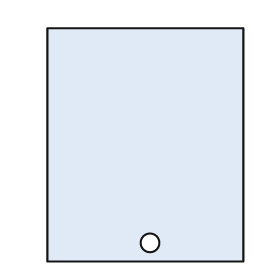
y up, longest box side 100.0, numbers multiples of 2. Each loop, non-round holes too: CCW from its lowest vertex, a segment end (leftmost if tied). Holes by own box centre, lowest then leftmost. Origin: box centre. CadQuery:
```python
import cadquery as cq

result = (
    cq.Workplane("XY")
    .moveTo(-42.0, -50.0)
    .lineTo(42.0, -50.0)
    .lineTo(42.0, 50.0)
    .lineTo(-42.0, 50.0)
    .close()
    .moveTo(2.0, -42.0)
    .circle(4.0)
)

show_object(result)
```